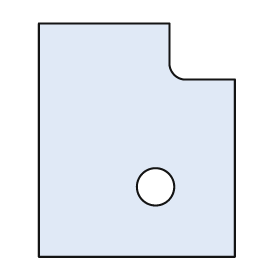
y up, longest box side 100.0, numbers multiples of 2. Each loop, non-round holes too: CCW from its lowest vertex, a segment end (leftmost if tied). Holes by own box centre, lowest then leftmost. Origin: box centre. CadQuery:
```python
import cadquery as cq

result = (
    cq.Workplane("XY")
    .moveTo(-42.0, -50.0)
    .lineTo(42.0, -50.0)
    .lineTo(42.0, 26.0)
    .lineTo(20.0, 26.0)
    .threePointArc((16.0, 28.0), (14.0, 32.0))
    .lineTo(14.0, 50.0)
    .lineTo(-42.0, 50.0)
    .close()
    .moveTo(8.0, -20.0)
    .circle(8.0)
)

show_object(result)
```